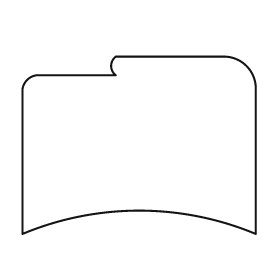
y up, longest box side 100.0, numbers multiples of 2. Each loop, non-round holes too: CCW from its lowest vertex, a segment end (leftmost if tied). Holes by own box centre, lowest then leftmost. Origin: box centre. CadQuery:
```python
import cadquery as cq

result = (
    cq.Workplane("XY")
    .moveTo(-50.0, -38.0)
    .threePointArc((0.0, -28.0), (50.0, -38.0))
    .lineTo(50.0, 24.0)
    .threePointArc((46.0, 34.0), (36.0, 38.0))
    .lineTo(-10.0, 38.0)
    .threePointArc((-12.0, 34.0), (-10.0, 30.0))
    .lineTo(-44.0, 30.0)
    .threePointArc((-48.0, 28.0), (-50.0, 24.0))
    .close()
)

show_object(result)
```